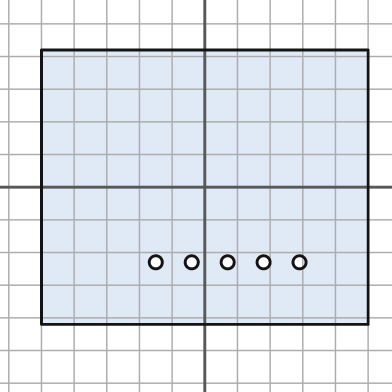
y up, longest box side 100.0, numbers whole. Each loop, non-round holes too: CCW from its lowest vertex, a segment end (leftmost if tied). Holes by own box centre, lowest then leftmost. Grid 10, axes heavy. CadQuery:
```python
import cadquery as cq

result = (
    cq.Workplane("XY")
    .moveTo(-50.0, -42.0)
    .lineTo(50.0, -42.0)
    .lineTo(50.0, 42.0)
    .lineTo(-50.0, 42.0)
    .close()
    .moveTo(-15.0, -23.0)
    .circle(2.0)
    .moveTo(-4.0, -23.0)
    .circle(2.0)
    .moveTo(7.0, -23.0)
    .circle(2.0)
    .moveTo(18.0, -23.0)
    .circle(2.0)
    .moveTo(29.0, -23.0)
    .circle(2.0)
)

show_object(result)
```